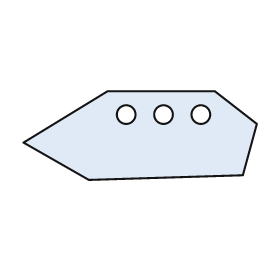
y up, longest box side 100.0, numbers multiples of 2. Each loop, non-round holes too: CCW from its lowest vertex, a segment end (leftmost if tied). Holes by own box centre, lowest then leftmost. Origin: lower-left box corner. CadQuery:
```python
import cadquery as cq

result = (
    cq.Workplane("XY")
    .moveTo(28.0, 0.0)
    .lineTo(94.0, 2.0)
    .lineTo(100.0, 24.0)
    .lineTo(82.0, 38.0)
    .lineTo(36.0, 38.0)
    .lineTo(0.0, 16.0)
    .close()
    .moveTo(44.0, 28.0)
    .circle(4.0)
    .moveTo(60.0, 28.0)
    .circle(4.0)
    .moveTo(76.0, 28.0)
    .circle(4.0)
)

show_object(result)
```